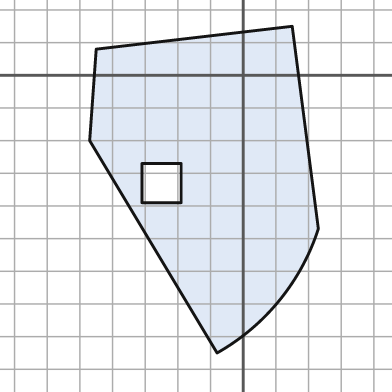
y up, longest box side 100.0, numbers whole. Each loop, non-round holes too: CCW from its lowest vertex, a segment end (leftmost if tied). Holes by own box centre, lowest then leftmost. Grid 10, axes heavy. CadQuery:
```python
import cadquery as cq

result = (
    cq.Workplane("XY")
    .moveTo(-8.0, -85.0)
    .threePointArc((11.0, -69.0), (23.0, -47.0))
    .lineTo(15.0, 15.0)
    .lineTo(-45.0, 8.0)
    .lineTo(-47.0, -20.0)
    .close()
    .moveTo(-31.0, -39.0)
    .lineTo(-19.0, -39.0)
    .lineTo(-19.0, -27.0)
    .lineTo(-31.0, -27.0)
    .close()
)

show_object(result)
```